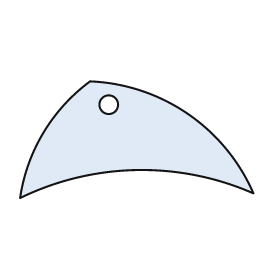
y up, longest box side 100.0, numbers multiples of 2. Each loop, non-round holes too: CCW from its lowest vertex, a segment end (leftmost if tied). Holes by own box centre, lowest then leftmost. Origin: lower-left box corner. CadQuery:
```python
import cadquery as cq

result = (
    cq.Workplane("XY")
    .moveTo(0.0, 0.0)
    .threePointArc((50.0, 12.0), (100.0, 2.0))
    .threePointArc((72.0, 36.0), (30.0, 50.0))
    .threePointArc((10.0, 28.0), (0.0, 0.0))
    .close()
    .moveTo(38.0, 40.0)
    .circle(4.0)
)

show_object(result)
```